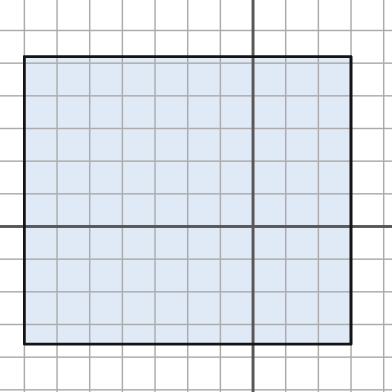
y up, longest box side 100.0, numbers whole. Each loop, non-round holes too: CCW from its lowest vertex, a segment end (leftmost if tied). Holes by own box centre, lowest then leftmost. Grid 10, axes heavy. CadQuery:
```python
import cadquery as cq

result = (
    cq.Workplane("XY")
    .moveTo(-70.0, -36.0)
    .lineTo(30.0, -36.0)
    .lineTo(30.0, 52.0)
    .lineTo(-70.0, 52.0)
    .close()
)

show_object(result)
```